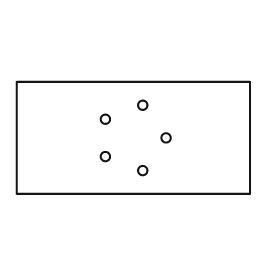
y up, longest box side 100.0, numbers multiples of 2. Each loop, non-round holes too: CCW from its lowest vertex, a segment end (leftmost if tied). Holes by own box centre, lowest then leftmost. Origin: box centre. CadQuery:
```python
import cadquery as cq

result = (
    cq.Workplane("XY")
    .moveTo(-50.0, -24.0)
    .lineTo(50.0, -24.0)
    .lineTo(50.0, 24.0)
    .lineTo(-50.0, 24.0)
    .close()
    .moveTo(4.0, -14.0)
    .circle(2.0)
    .moveTo(-12.0, -8.0)
    .circle(2.0)
    .moveTo(14.0, 0.0)
    .circle(2.0)
    .moveTo(-12.0, 8.0)
    .circle(2.0)
    .moveTo(4.0, 14.0)
    .circle(2.0)
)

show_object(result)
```